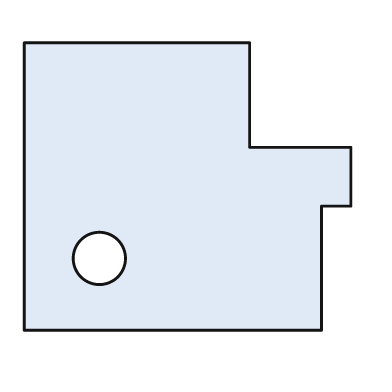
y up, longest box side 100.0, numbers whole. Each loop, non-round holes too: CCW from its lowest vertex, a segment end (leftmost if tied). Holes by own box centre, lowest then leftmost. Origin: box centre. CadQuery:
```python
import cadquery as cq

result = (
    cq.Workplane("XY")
    .moveTo(-50.0, -44.0)
    .lineTo(41.0, -44.0)
    .lineTo(41.0, -6.0)
    .lineTo(50.0, -6.0)
    .lineTo(50.0, 12.0)
    .lineTo(19.0, 12.0)
    .lineTo(19.0, 44.0)
    .lineTo(-50.0, 44.0)
    .close()
    .moveTo(-27.0, -22.0)
    .circle(8.0)
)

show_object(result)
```